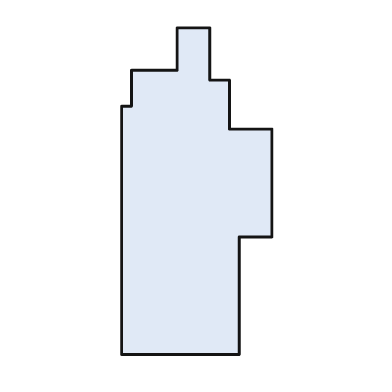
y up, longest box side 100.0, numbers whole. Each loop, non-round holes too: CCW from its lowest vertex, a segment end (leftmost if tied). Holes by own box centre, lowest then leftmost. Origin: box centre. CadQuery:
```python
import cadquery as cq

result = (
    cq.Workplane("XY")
    .moveTo(-23.0, -50.0)
    .lineTo(13.0, -50.0)
    .lineTo(13.0, -14.0)
    .lineTo(23.0, -14.0)
    .lineTo(23.0, 19.0)
    .lineTo(10.0, 19.0)
    .lineTo(10.0, 34.0)
    .lineTo(4.0, 34.0)
    .lineTo(4.0, 50.0)
    .lineTo(-6.0, 50.0)
    .lineTo(-6.0, 37.0)
    .lineTo(-20.0, 37.0)
    .lineTo(-20.0, 26.0)
    .lineTo(-23.0, 26.0)
    .close()
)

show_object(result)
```